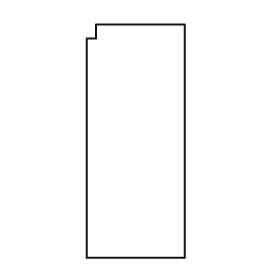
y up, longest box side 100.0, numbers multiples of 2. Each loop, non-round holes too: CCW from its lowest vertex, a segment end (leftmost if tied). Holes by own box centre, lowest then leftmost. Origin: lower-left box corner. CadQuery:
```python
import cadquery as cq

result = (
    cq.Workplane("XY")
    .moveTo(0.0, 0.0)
    .lineTo(42.0, 0.0)
    .lineTo(42.0, 100.0)
    .lineTo(4.0, 100.0)
    .lineTo(4.0, 94.0)
    .lineTo(0.0, 94.0)
    .close()
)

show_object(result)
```